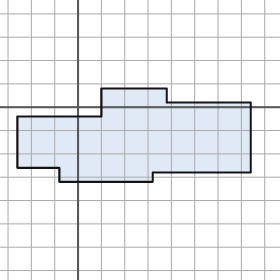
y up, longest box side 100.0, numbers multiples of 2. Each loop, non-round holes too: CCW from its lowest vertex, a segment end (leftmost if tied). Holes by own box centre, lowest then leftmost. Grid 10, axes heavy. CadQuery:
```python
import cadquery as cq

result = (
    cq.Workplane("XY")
    .moveTo(-8.0, -32.0)
    .lineTo(32.0, -32.0)
    .lineTo(32.0, -28.0)
    .lineTo(74.0, -28.0)
    .lineTo(74.0, 2.0)
    .lineTo(38.0, 2.0)
    .lineTo(38.0, 8.0)
    .lineTo(10.0, 8.0)
    .lineTo(10.0, -4.0)
    .lineTo(-26.0, -4.0)
    .lineTo(-26.0, -26.0)
    .lineTo(-8.0, -26.0)
    .close()
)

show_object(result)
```